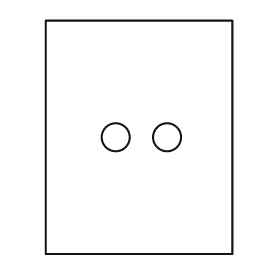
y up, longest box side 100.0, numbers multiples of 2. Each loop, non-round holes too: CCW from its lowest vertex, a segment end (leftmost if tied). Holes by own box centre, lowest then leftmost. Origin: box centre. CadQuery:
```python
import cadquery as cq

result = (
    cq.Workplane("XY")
    .moveTo(-40.0, -50.0)
    .lineTo(40.0, -50.0)
    .lineTo(40.0, 50.0)
    .lineTo(-40.0, 50.0)
    .close()
    .moveTo(-10.0, 0.0)
    .circle(6.0)
    .moveTo(12.0, 0.0)
    .circle(6.0)
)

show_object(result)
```